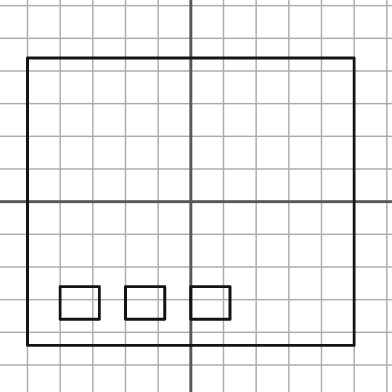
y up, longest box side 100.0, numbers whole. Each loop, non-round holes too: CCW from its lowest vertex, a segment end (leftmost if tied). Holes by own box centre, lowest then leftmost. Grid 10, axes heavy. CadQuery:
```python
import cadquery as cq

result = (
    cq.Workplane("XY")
    .moveTo(-50.0, -44.0)
    .lineTo(50.0, -44.0)
    .lineTo(50.0, 44.0)
    .lineTo(-50.0, 44.0)
    .close()
    .moveTo(-40.0, -36.0)
    .lineTo(-28.0, -36.0)
    .lineTo(-28.0, -26.0)
    .lineTo(-40.0, -26.0)
    .close()
    .moveTo(-20.0, -36.0)
    .lineTo(-8.0, -36.0)
    .lineTo(-8.0, -26.0)
    .lineTo(-20.0, -26.0)
    .close()
    .moveTo(0.0, -36.0)
    .lineTo(12.0, -36.0)
    .lineTo(12.0, -26.0)
    .lineTo(0.0, -26.0)
    .close()
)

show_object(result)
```